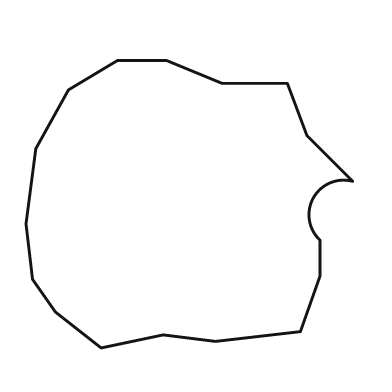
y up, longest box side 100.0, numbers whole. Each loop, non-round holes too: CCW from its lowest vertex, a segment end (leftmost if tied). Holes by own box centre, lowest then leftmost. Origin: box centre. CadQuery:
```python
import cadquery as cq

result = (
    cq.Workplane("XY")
    .moveTo(-27.0, -44.0)
    .lineTo(-8.0, -40.0)
    .lineTo(8.0, -42.0)
    .lineTo(34.0, -39.0)
    .lineTo(40.0, -22.0)
    .lineTo(40.0, -11.0)
    .threePointArc((38.0, 2.0), (50.0, 7.0))
    .lineTo(36.0, 21.0)
    .lineTo(30.0, 37.0)
    .lineTo(10.0, 37.0)
    .lineTo(-7.0, 44.0)
    .lineTo(-22.0, 44.0)
    .lineTo(-37.0, 35.0)
    .lineTo(-47.0, 17.0)
    .lineTo(-50.0, -6.0)
    .lineTo(-48.0, -23.0)
    .lineTo(-41.0, -33.0)
    .close()
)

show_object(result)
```